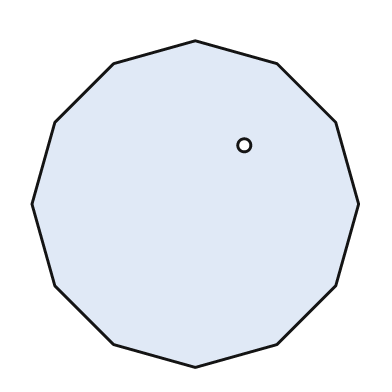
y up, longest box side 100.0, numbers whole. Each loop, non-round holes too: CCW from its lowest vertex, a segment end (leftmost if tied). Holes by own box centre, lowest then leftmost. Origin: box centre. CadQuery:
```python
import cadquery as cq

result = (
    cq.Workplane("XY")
    .moveTo(0.0, -50.0)
    .lineTo(25.0, -43.0)
    .lineTo(43.0, -25.0)
    .lineTo(50.0, 0.0)
    .lineTo(43.0, 25.0)
    .lineTo(25.0, 43.0)
    .lineTo(0.0, 50.0)
    .lineTo(-25.0, 43.0)
    .lineTo(-43.0, 25.0)
    .lineTo(-50.0, 0.0)
    .lineTo(-43.0, -25.0)
    .lineTo(-25.0, -43.0)
    .close()
    .moveTo(15.0, 18.0)
    .circle(2.0)
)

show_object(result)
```